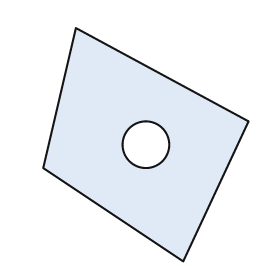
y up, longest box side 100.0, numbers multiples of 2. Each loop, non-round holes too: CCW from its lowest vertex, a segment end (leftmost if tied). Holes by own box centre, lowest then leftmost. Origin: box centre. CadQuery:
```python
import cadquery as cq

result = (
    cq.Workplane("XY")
    .moveTo(16.0, -50.0)
    .lineTo(44.0, 10.0)
    .lineTo(-30.0, 50.0)
    .lineTo(-44.0, -10.0)
    .close()
    .moveTo(0.0, 0.0)
    .circle(10.0)
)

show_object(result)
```